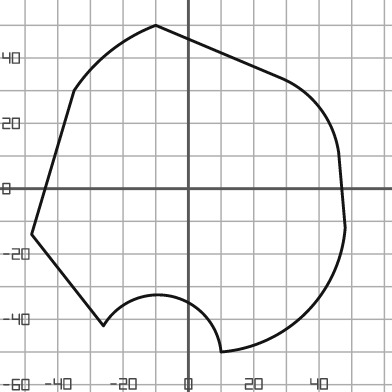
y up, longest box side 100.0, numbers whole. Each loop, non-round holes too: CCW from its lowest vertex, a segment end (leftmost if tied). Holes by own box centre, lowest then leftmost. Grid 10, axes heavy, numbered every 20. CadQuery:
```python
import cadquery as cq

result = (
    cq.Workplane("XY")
    .moveTo(10.0, -50.0)
    .threePointArc((36.0, -38.0), (48.0, -12.0))
    .lineTo(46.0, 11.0)
    .threePointArc((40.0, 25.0), (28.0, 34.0))
    .lineTo(-10.0, 50.0)
    .threePointArc((-24.0, 42.0), (-35.0, 30.0))
    .lineTo(-48.0, -14.0)
    .lineTo(-26.0, -42.0)
    .threePointArc((-5.0, -33.0), (10.0, -50.0))
    .close()
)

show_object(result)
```